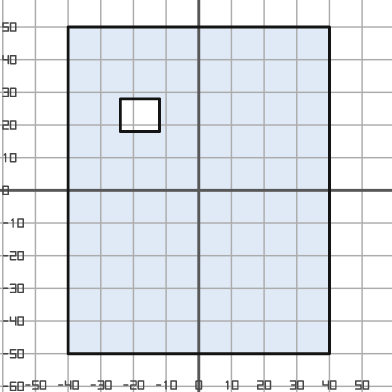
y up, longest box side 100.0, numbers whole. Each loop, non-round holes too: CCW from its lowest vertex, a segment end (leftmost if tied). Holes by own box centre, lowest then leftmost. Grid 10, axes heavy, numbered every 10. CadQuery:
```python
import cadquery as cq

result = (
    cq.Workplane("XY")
    .moveTo(-40.0, -50.0)
    .lineTo(40.0, -50.0)
    .lineTo(40.0, 50.0)
    .lineTo(-40.0, 50.0)
    .close()
    .moveTo(-24.0, 18.0)
    .lineTo(-12.0, 18.0)
    .lineTo(-12.0, 28.0)
    .lineTo(-24.0, 28.0)
    .close()
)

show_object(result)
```